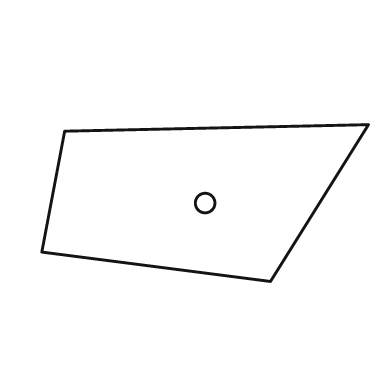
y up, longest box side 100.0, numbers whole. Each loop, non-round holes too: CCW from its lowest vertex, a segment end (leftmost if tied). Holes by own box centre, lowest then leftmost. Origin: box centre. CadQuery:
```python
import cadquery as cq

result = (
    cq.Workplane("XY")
    .moveTo(20.0, -24.0)
    .lineTo(50.0, 24.0)
    .lineTo(-43.0, 22.0)
    .lineTo(-50.0, -15.0)
    .close()
    .moveTo(0.0, 0.0)
    .circle(3.0)
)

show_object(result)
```